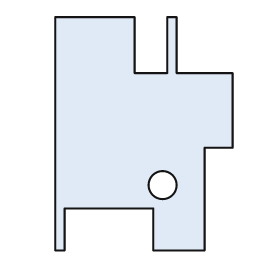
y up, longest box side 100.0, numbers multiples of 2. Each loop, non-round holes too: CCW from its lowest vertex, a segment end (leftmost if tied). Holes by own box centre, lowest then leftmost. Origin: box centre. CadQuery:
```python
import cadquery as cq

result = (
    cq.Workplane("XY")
    .moveTo(-38.0, -50.0)
    .lineTo(-34.0, -50.0)
    .lineTo(-34.0, -32.0)
    .lineTo(4.0, -32.0)
    .lineTo(4.0, -50.0)
    .lineTo(26.0, -50.0)
    .lineTo(26.0, -6.0)
    .lineTo(38.0, -6.0)
    .lineTo(38.0, 26.0)
    .lineTo(14.0, 26.0)
    .lineTo(14.0, 50.0)
    .lineTo(10.0, 50.0)
    .lineTo(10.0, 26.0)
    .lineTo(-4.0, 26.0)
    .lineTo(-4.0, 50.0)
    .lineTo(-38.0, 50.0)
    .close()
    .moveTo(8.0, -22.0)
    .circle(6.0)
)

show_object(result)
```